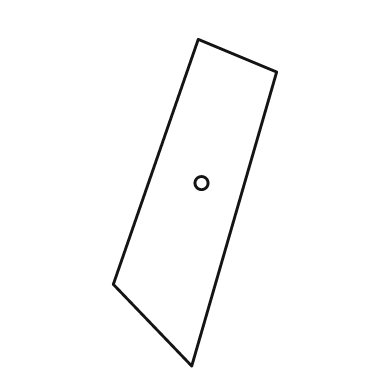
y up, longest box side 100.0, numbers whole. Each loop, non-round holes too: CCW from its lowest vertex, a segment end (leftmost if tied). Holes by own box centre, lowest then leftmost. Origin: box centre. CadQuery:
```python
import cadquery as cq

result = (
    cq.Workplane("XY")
    .moveTo(-1.0, -50.0)
    .lineTo(25.0, 40.0)
    .lineTo(1.0, 50.0)
    .lineTo(-25.0, -25.0)
    .close()
    .moveTo(2.0, 6.0)
    .circle(2.0)
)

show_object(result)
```